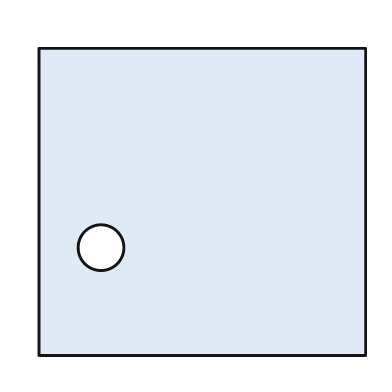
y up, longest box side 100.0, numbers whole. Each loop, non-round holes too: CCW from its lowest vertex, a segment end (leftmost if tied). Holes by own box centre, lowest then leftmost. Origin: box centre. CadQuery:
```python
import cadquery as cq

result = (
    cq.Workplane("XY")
    .moveTo(-50.0, -47.0)
    .lineTo(50.0, -47.0)
    .lineTo(50.0, 47.0)
    .lineTo(-50.0, 47.0)
    .close()
    .moveTo(-31.0, -14.0)
    .circle(7.0)
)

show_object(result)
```